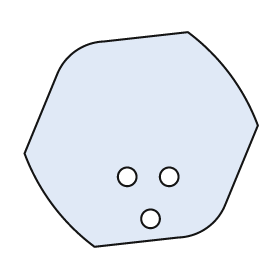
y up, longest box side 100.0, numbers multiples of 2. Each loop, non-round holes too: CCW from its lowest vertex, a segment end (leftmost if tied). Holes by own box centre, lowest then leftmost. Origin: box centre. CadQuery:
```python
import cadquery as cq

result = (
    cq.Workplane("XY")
    .moveTo(-20.0, -46.0)
    .lineTo(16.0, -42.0)
    .threePointArc((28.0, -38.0), (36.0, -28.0))
    .lineTo(50.0, 6.0)
    .threePointArc((38.0, 28.0), (20.0, 46.0))
    .lineTo(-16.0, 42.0)
    .threePointArc((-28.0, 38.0), (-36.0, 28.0))
    .lineTo(-50.0, -6.0)
    .threePointArc((-38.0, -28.0), (-20.0, -46.0))
    .close()
    .moveTo(4.0, -34.0)
    .circle(4.0)
    .moveTo(-6.0, -16.0)
    .circle(4.0)
    .moveTo(12.0, -16.0)
    .circle(4.0)
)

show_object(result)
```